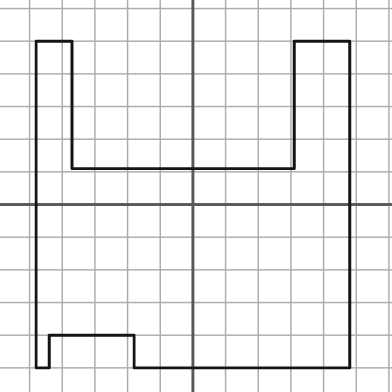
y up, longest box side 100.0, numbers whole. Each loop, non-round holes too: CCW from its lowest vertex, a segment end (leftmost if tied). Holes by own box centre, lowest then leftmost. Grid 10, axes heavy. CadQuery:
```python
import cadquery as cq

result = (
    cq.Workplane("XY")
    .moveTo(-48.0, -50.0)
    .lineTo(-44.0, -50.0)
    .lineTo(-44.0, -40.0)
    .lineTo(-18.0, -40.0)
    .lineTo(-18.0, -50.0)
    .lineTo(48.0, -50.0)
    .lineTo(48.0, 50.0)
    .lineTo(31.0, 50.0)
    .lineTo(31.0, 11.0)
    .lineTo(-37.0, 11.0)
    .lineTo(-37.0, 50.0)
    .lineTo(-48.0, 50.0)
    .close()
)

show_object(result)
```